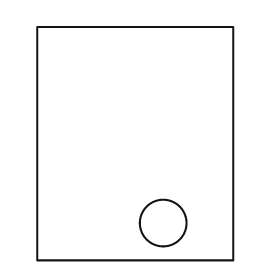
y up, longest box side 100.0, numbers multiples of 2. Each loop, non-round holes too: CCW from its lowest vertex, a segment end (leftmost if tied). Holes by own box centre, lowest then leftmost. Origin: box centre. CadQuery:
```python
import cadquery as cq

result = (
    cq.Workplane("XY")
    .moveTo(-42.0, -50.0)
    .lineTo(42.0, -50.0)
    .lineTo(42.0, 50.0)
    .lineTo(-42.0, 50.0)
    .close()
    .moveTo(12.0, -34.0)
    .circle(10.0)
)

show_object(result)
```